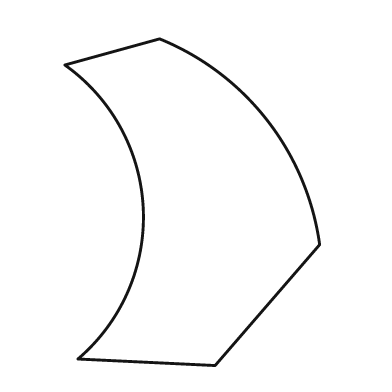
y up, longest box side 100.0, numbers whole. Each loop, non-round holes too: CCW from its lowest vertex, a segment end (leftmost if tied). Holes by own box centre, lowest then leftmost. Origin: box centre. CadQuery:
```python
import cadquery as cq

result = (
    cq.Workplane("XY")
    .moveTo(7.0, -50.0)
    .lineTo(39.0, -13.0)
    .threePointArc((23.0, 25.0), (-10.0, 50.0))
    .lineTo(-39.0, 42.0)
    .threePointArc((-15.0, -2.0), (-35.0, -48.0))
    .close()
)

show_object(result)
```